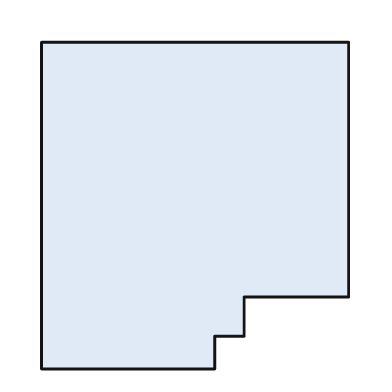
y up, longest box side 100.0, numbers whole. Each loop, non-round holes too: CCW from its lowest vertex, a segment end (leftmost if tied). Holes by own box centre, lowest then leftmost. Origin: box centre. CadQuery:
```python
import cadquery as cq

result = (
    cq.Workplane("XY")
    .moveTo(-47.0, -50.0)
    .lineTo(6.0, -50.0)
    .lineTo(6.0, -40.0)
    .lineTo(15.0, -40.0)
    .lineTo(15.0, -28.0)
    .lineTo(47.0, -28.0)
    .lineTo(47.0, 50.0)
    .lineTo(-47.0, 50.0)
    .close()
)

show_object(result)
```